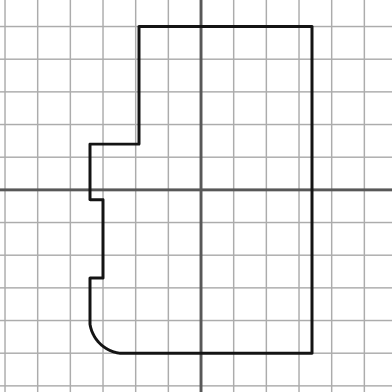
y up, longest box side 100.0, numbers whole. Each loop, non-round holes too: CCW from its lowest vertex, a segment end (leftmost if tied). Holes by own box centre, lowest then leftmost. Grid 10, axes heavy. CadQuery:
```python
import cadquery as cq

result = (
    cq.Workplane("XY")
    .moveTo(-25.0, -50.0)
    .lineTo(34.0, -50.0)
    .lineTo(34.0, 50.0)
    .lineTo(-19.0, 50.0)
    .lineTo(-19.0, 14.0)
    .lineTo(-34.0, 14.0)
    .lineTo(-34.0, -3.0)
    .lineTo(-30.0, -3.0)
    .lineTo(-30.0, -27.0)
    .lineTo(-34.0, -27.0)
    .lineTo(-34.0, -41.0)
    .threePointArc((-31.0, -47.0), (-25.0, -50.0))
    .close()
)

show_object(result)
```